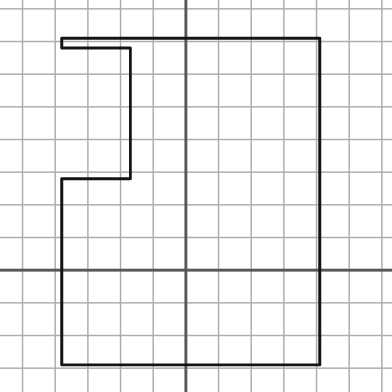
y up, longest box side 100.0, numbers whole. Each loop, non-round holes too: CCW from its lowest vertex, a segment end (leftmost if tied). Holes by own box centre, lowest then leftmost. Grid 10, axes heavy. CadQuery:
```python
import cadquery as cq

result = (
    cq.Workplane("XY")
    .moveTo(-38.0, -29.0)
    .lineTo(41.0, -29.0)
    .lineTo(41.0, 71.0)
    .lineTo(-38.0, 71.0)
    .lineTo(-38.0, 68.0)
    .lineTo(-17.0, 68.0)
    .lineTo(-17.0, 28.0)
    .lineTo(-38.0, 28.0)
    .close()
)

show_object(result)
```